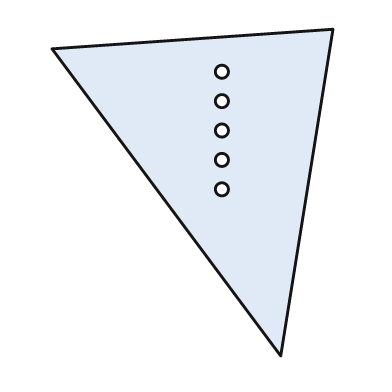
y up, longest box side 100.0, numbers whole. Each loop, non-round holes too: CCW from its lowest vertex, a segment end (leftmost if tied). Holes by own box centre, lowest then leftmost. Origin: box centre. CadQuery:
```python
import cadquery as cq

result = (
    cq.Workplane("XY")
    .moveTo(27.0, -50.0)
    .lineTo(43.0, 50.0)
    .lineTo(-43.0, 44.0)
    .close()
    .moveTo(9.0, 1.0)
    .circle(2.0)
    .moveTo(9.0, 10.0)
    .circle(2.0)
    .moveTo(9.0, 19.0)
    .circle(2.0)
    .moveTo(9.0, 28.0)
    .circle(2.0)
    .moveTo(9.0, 37.0)
    .circle(2.0)
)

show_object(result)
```